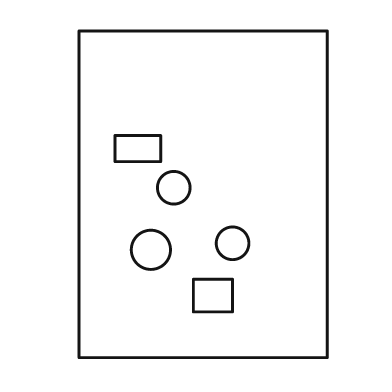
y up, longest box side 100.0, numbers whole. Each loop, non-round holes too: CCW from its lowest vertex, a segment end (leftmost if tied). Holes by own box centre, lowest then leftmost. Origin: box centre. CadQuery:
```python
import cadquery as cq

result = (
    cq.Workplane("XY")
    .moveTo(-38.0, -50.0)
    .lineTo(38.0, -50.0)
    .lineTo(38.0, 50.0)
    .lineTo(-38.0, 50.0)
    .close()
    .moveTo(-3.0, -36.0)
    .lineTo(9.0, -36.0)
    .lineTo(9.0, -26.0)
    .lineTo(-3.0, -26.0)
    .close()
    .moveTo(-16.0, -17.0)
    .circle(6.0)
    .moveTo(9.0, -15.0)
    .circle(5.0)
    .moveTo(-9.0, 2.0)
    .circle(5.0)
    .moveTo(-27.0, 10.0)
    .lineTo(-13.0, 10.0)
    .lineTo(-13.0, 18.0)
    .lineTo(-27.0, 18.0)
    .close()
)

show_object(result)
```